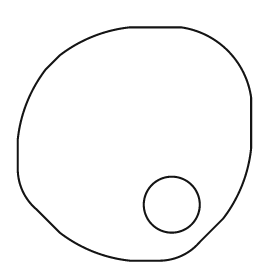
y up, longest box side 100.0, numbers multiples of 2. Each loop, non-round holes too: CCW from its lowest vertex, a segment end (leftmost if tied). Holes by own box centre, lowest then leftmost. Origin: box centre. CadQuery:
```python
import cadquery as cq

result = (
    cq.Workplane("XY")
    .moveTo(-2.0, -50.0)
    .lineTo(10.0, -50.0)
    .threePointArc((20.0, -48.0), (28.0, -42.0))
    .lineTo(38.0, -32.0)
    .threePointArc((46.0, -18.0), (50.0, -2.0))
    .lineTo(50.0, 20.0)
    .threePointArc((40.0, 40.0), (20.0, 50.0))
    .lineTo(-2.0, 50.0)
    .threePointArc((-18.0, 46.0), (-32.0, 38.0))
    .lineTo(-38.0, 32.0)
    .threePointArc((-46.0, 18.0), (-50.0, 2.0))
    .lineTo(-50.0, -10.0)
    .threePointArc((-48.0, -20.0), (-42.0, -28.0))
    .lineTo(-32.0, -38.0)
    .threePointArc((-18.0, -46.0), (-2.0, -50.0))
    .close()
    .moveTo(16.0, -26.0)
    .circle(12.0)
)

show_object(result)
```